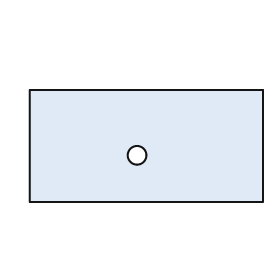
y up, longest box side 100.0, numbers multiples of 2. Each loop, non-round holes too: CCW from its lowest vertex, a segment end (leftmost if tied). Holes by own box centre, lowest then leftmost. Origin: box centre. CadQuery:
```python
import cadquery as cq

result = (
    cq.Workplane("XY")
    .moveTo(-50.0, -24.0)
    .lineTo(50.0, -24.0)
    .lineTo(50.0, 24.0)
    .lineTo(-50.0, 24.0)
    .close()
    .moveTo(-4.0, -4.0)
    .circle(4.0)
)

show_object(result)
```